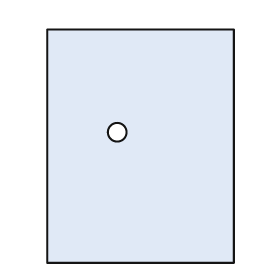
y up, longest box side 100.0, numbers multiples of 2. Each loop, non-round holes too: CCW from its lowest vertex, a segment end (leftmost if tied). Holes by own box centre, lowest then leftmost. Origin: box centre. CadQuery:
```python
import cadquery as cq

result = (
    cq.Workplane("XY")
    .moveTo(-40.0, -50.0)
    .lineTo(40.0, -50.0)
    .lineTo(40.0, 50.0)
    .lineTo(-40.0, 50.0)
    .close()
    .moveTo(-10.0, 6.0)
    .circle(4.0)
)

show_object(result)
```